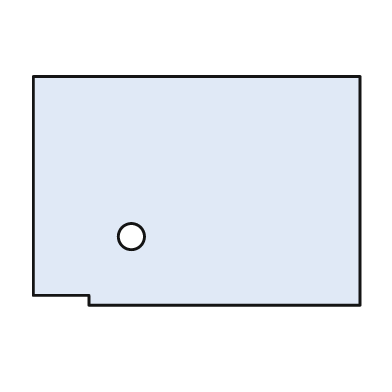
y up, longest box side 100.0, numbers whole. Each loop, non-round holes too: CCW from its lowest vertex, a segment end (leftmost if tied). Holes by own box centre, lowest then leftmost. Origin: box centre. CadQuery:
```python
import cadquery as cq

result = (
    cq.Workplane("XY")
    .moveTo(-33.0, -35.0)
    .lineTo(50.0, -35.0)
    .lineTo(50.0, 35.0)
    .lineTo(-50.0, 35.0)
    .lineTo(-50.0, -32.0)
    .lineTo(-33.0, -32.0)
    .close()
    .moveTo(-20.0, -14.0)
    .circle(4.0)
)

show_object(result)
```